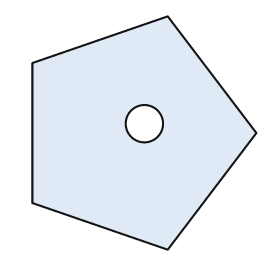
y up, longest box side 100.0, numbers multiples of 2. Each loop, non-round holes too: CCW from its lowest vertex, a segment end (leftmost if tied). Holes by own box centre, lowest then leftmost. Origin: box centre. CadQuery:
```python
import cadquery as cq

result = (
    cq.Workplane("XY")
    .moveTo(10.0, -50.0)
    .lineTo(48.0, 0.0)
    .lineTo(10.0, 50.0)
    .lineTo(-48.0, 30.0)
    .lineTo(-48.0, -30.0)
    .close()
    .moveTo(0.0, 4.0)
    .circle(8.0)
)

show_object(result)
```